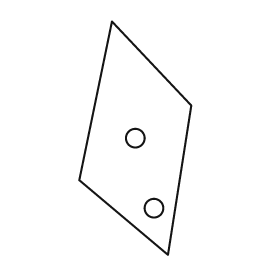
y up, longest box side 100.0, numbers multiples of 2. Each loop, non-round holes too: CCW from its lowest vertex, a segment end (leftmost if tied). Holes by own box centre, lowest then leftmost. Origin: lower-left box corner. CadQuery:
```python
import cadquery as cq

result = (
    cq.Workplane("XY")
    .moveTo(38.0, 0.0)
    .lineTo(48.0, 64.0)
    .lineTo(14.0, 100.0)
    .lineTo(0.0, 32.0)
    .close()
    .moveTo(32.0, 20.0)
    .circle(4.0)
    .moveTo(24.0, 50.0)
    .circle(4.0)
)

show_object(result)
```